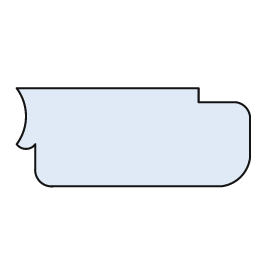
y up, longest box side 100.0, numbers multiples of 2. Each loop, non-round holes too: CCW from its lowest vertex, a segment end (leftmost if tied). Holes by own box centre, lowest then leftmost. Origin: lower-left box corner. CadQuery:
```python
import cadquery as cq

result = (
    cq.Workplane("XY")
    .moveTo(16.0, 0.0)
    .lineTo(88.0, 0.0)
    .threePointArc((96.0, 4.0), (100.0, 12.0))
    .lineTo(100.0, 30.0)
    .threePointArc((98.0, 34.0), (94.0, 36.0))
    .lineTo(78.0, 36.0)
    .lineTo(78.0, 42.0)
    .lineTo(0.0, 42.0)
    .threePointArc((4.0, 30.0), (0.0, 18.0))
    .threePointArc((4.0, 16.0), (8.0, 18.0))
    .lineTo(8.0, 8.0)
    .threePointArc((10.0, 2.0), (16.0, 0.0))
    .close()
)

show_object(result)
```